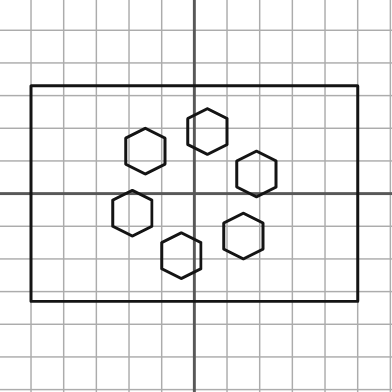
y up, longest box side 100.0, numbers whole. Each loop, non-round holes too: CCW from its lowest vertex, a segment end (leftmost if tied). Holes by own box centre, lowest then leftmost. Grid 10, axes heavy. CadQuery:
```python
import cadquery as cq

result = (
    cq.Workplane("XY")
    .moveTo(-50.0, -33.0)
    .lineTo(50.0, -33.0)
    .lineTo(50.0, 33.0)
    .lineTo(-50.0, 33.0)
    .close()
    .moveTo(-4.0, -26.0)
    .lineTo(2.0, -23.0)
    .lineTo(2.0, -15.0)
    .lineTo(-4.0, -12.0)
    .lineTo(-10.0, -15.0)
    .lineTo(-10.0, -23.0)
    .close()
    .moveTo(15.0, -20.0)
    .lineTo(21.0, -17.0)
    .lineTo(21.0, -9.0)
    .lineTo(15.0, -6.0)
    .lineTo(9.0, -9.0)
    .lineTo(9.0, -17.0)
    .close()
    .moveTo(-19.0, -13.0)
    .lineTo(-13.0, -10.0)
    .lineTo(-13.0, -2.0)
    .lineTo(-19.0, 1.0)
    .lineTo(-25.0, -2.0)
    .lineTo(-25.0, -10.0)
    .close()
    .moveTo(19.0, -1.0)
    .lineTo(25.0, 2.0)
    .lineTo(25.0, 10.0)
    .lineTo(19.0, 13.0)
    .lineTo(13.0, 10.0)
    .lineTo(13.0, 2.0)
    .close()
    .moveTo(-15.0, 6.0)
    .lineTo(-9.0, 9.0)
    .lineTo(-9.0, 17.0)
    .lineTo(-15.0, 20.0)
    .lineTo(-21.0, 17.0)
    .lineTo(-21.0, 9.0)
    .close()
    .moveTo(4.0, 12.0)
    .lineTo(10.0, 15.0)
    .lineTo(10.0, 23.0)
    .lineTo(4.0, 26.0)
    .lineTo(-2.0, 23.0)
    .lineTo(-2.0, 15.0)
    .close()
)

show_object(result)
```